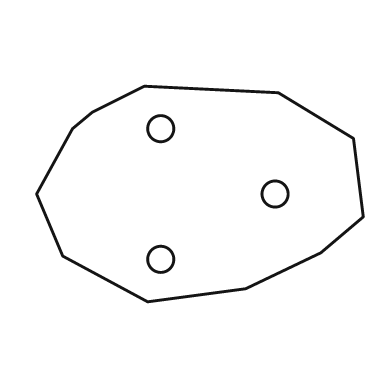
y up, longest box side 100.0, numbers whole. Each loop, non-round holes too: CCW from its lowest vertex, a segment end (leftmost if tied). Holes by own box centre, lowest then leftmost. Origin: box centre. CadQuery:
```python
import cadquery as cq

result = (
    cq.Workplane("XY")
    .moveTo(-16.0, -33.0)
    .lineTo(14.0, -29.0)
    .lineTo(37.0, -18.0)
    .lineTo(50.0, -7.0)
    .lineTo(47.0, 17.0)
    .lineTo(24.0, 31.0)
    .lineTo(-17.0, 33.0)
    .lineTo(-33.0, 25.0)
    .lineTo(-39.0, 20.0)
    .lineTo(-50.0, 0.0)
    .lineTo(-42.0, -19.0)
    .close()
    .moveTo(-12.0, -20.0)
    .circle(4.0)
    .moveTo(23.0, 0.0)
    .circle(4.0)
    .moveTo(-12.0, 20.0)
    .circle(4.0)
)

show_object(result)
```